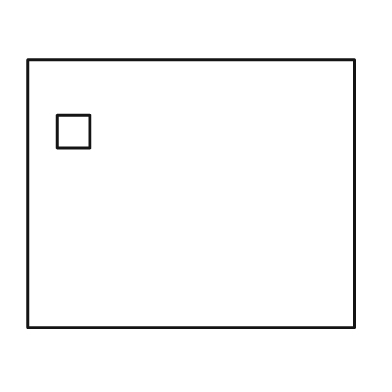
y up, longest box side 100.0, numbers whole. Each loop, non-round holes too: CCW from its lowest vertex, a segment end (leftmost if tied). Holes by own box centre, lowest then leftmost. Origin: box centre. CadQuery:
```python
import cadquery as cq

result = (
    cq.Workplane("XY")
    .moveTo(-50.0, -41.0)
    .lineTo(50.0, -41.0)
    .lineTo(50.0, 41.0)
    .lineTo(-50.0, 41.0)
    .close()
    .moveTo(-41.0, 14.0)
    .lineTo(-31.0, 14.0)
    .lineTo(-31.0, 24.0)
    .lineTo(-41.0, 24.0)
    .close()
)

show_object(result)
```